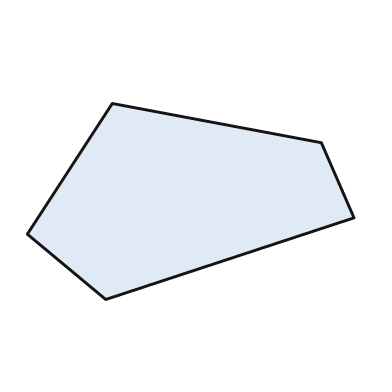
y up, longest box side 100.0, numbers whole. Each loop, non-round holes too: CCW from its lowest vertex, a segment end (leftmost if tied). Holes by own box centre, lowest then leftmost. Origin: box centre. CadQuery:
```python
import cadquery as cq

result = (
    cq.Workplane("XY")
    .moveTo(-26.0, -30.0)
    .lineTo(50.0, -5.0)
    .lineTo(40.0, 18.0)
    .lineTo(-24.0, 30.0)
    .lineTo(-50.0, -10.0)
    .close()
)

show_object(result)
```